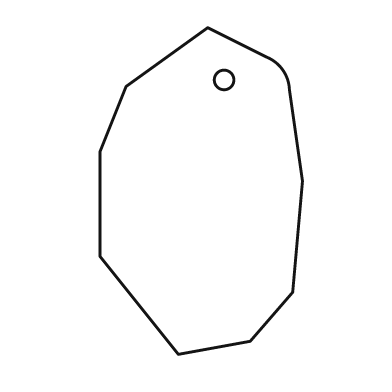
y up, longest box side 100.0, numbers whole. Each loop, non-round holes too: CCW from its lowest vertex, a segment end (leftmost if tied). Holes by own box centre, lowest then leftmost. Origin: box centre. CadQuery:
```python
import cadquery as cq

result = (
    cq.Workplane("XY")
    .moveTo(-7.0, -50.0)
    .lineTo(15.0, -46.0)
    .lineTo(28.0, -31.0)
    .lineTo(31.0, 3.0)
    .lineTo(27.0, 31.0)
    .threePointArc((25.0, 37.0), (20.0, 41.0))
    .lineTo(2.0, 50.0)
    .lineTo(-23.0, 32.0)
    .lineTo(-31.0, 12.0)
    .lineTo(-31.0, -20.0)
    .close()
    .moveTo(7.0, 34.0)
    .circle(3.0)
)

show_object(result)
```